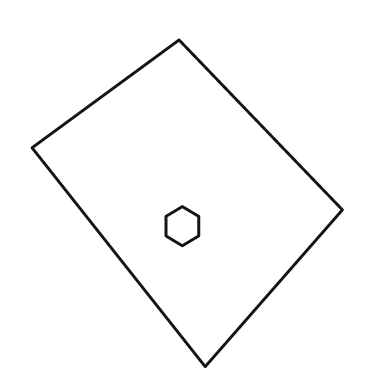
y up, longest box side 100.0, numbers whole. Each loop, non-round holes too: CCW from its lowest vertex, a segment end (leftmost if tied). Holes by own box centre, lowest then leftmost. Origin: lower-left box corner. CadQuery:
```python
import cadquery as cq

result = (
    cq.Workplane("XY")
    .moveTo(53.0, 0.0)
    .lineTo(95.0, 48.0)
    .lineTo(45.0, 100.0)
    .lineTo(0.0, 67.0)
    .close()
    .moveTo(46.0, 37.0)
    .lineTo(51.0, 40.0)
    .lineTo(51.0, 46.0)
    .lineTo(46.0, 49.0)
    .lineTo(41.0, 46.0)
    .lineTo(41.0, 40.0)
    .close()
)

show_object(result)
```